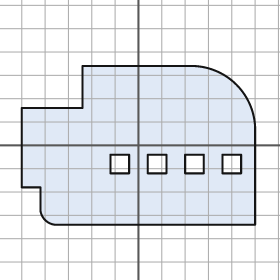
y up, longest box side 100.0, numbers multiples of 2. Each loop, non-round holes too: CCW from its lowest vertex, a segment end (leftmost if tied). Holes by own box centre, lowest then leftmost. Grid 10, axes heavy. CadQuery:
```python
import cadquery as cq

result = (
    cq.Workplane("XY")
    .moveTo(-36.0, -34.0)
    .lineTo(50.0, -34.0)
    .lineTo(50.0, 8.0)
    .threePointArc((42.0, 26.0), (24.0, 34.0))
    .lineTo(-24.0, 34.0)
    .lineTo(-24.0, 16.0)
    .lineTo(-50.0, 16.0)
    .lineTo(-50.0, -18.0)
    .lineTo(-42.0, -18.0)
    .lineTo(-42.0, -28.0)
    .threePointArc((-40.0, -32.0), (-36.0, -34.0))
    .close()
    .moveTo(-12.0, -12.0)
    .lineTo(-4.0, -12.0)
    .lineTo(-4.0, -4.0)
    .lineTo(-12.0, -4.0)
    .close()
    .moveTo(4.0, -12.0)
    .lineTo(12.0, -12.0)
    .lineTo(12.0, -4.0)
    .lineTo(4.0, -4.0)
    .close()
    .moveTo(20.0, -12.0)
    .lineTo(28.0, -12.0)
    .lineTo(28.0, -4.0)
    .lineTo(20.0, -4.0)
    .close()
    .moveTo(36.0, -12.0)
    .lineTo(44.0, -12.0)
    .lineTo(44.0, -4.0)
    .lineTo(36.0, -4.0)
    .close()
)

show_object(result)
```